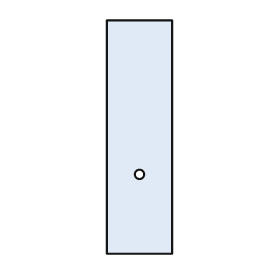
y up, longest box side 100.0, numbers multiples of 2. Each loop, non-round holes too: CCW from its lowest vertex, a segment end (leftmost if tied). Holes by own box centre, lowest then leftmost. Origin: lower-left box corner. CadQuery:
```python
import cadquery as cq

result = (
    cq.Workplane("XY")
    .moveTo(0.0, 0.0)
    .lineTo(28.0, 0.0)
    .lineTo(28.0, 100.0)
    .lineTo(0.0, 100.0)
    .close()
    .moveTo(14.0, 34.0)
    .circle(2.0)
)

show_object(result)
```